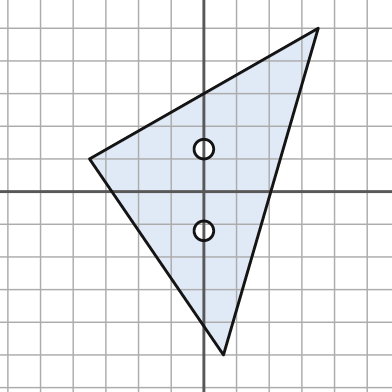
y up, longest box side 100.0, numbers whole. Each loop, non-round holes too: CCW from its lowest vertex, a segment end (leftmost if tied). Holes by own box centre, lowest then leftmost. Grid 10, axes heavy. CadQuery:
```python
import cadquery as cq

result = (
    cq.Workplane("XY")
    .moveTo(6.0, -50.0)
    .lineTo(35.0, 50.0)
    .lineTo(-35.0, 10.0)
    .close()
    .moveTo(0.0, -12.0)
    .circle(3.0)
    .moveTo(0.0, 13.0)
    .circle(3.0)
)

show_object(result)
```